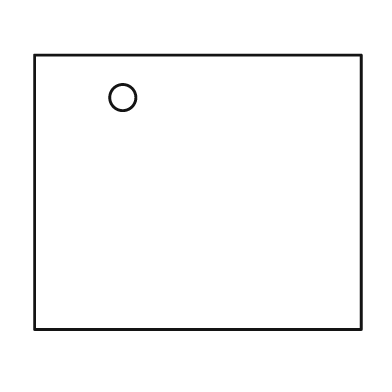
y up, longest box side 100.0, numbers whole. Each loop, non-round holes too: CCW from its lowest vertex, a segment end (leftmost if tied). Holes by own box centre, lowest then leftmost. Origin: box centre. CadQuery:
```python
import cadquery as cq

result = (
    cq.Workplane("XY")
    .moveTo(-50.0, -42.0)
    .lineTo(50.0, -42.0)
    .lineTo(50.0, 42.0)
    .lineTo(-50.0, 42.0)
    .close()
    .moveTo(-23.0, 29.0)
    .circle(4.0)
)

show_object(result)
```